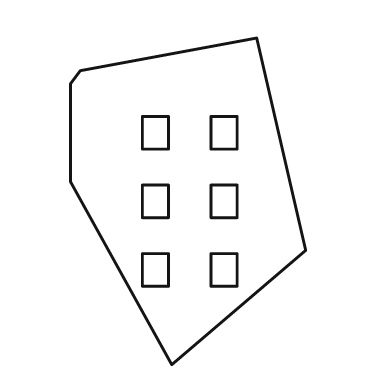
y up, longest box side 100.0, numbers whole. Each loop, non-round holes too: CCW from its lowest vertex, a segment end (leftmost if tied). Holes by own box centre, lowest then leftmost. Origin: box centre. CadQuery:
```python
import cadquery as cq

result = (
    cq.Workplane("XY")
    .moveTo(-5.0, -50.0)
    .lineTo(36.0, -15.0)
    .lineTo(21.0, 50.0)
    .lineTo(-33.0, 40.0)
    .lineTo(-36.0, 36.0)
    .lineTo(-36.0, 6.0)
    .close()
    .moveTo(-14.0, -26.0)
    .lineTo(-6.0, -26.0)
    .lineTo(-6.0, -16.0)
    .lineTo(-14.0, -16.0)
    .close()
    .moveTo(7.0, -26.0)
    .lineTo(15.0, -26.0)
    .lineTo(15.0, -16.0)
    .lineTo(7.0, -16.0)
    .close()
    .moveTo(-14.0, -5.0)
    .lineTo(-6.0, -5.0)
    .lineTo(-6.0, 5.0)
    .lineTo(-14.0, 5.0)
    .close()
    .moveTo(7.0, -5.0)
    .lineTo(15.0, -5.0)
    .lineTo(15.0, 5.0)
    .lineTo(7.0, 5.0)
    .close()
    .moveTo(-14.0, 16.0)
    .lineTo(-6.0, 16.0)
    .lineTo(-6.0, 26.0)
    .lineTo(-14.0, 26.0)
    .close()
    .moveTo(7.0, 16.0)
    .lineTo(15.0, 16.0)
    .lineTo(15.0, 26.0)
    .lineTo(7.0, 26.0)
    .close()
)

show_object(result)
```